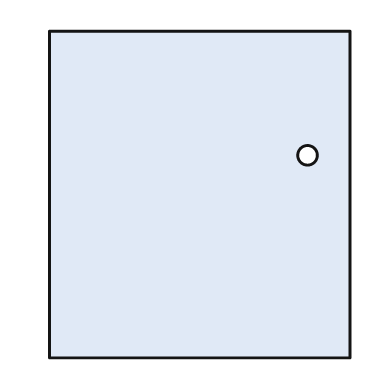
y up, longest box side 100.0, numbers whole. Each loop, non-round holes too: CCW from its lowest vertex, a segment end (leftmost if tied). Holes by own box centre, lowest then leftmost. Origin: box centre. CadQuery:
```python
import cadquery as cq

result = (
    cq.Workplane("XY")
    .moveTo(-46.0, -50.0)
    .lineTo(46.0, -50.0)
    .lineTo(46.0, 50.0)
    .lineTo(-46.0, 50.0)
    .close()
    .moveTo(33.0, 12.0)
    .circle(3.0)
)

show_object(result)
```